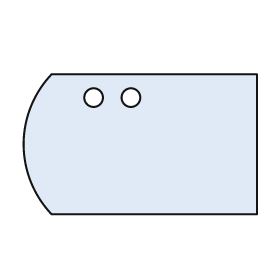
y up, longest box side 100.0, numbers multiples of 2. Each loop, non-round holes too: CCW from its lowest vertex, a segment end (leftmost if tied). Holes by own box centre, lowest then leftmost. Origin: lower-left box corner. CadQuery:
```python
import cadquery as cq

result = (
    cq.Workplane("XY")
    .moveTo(12.0, 0.0)
    .lineTo(100.0, 0.0)
    .lineTo(100.0, 60.0)
    .lineTo(12.0, 60.0)
    .threePointArc((0.0, 30.0), (12.0, 0.0))
    .close()
    .moveTo(30.0, 50.0)
    .circle(4.0)
    .moveTo(46.0, 50.0)
    .circle(4.0)
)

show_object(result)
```